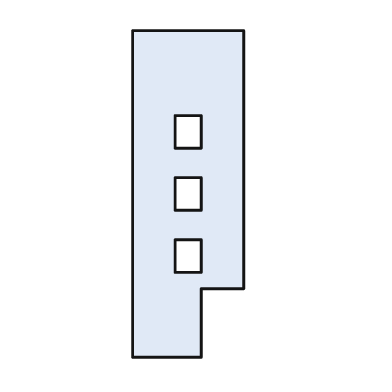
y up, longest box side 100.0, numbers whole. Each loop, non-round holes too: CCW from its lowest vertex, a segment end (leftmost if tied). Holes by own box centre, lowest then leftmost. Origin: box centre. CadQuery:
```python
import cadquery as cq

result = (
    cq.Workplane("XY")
    .moveTo(-17.0, -50.0)
    .lineTo(4.0, -50.0)
    .lineTo(4.0, -29.0)
    .lineTo(17.0, -29.0)
    .lineTo(17.0, 50.0)
    .lineTo(-17.0, 50.0)
    .close()
    .moveTo(-4.0, -24.0)
    .lineTo(4.0, -24.0)
    .lineTo(4.0, -14.0)
    .lineTo(-4.0, -14.0)
    .close()
    .moveTo(-4.0, -5.0)
    .lineTo(4.0, -5.0)
    .lineTo(4.0, 5.0)
    .lineTo(-4.0, 5.0)
    .close()
    .moveTo(-4.0, 14.0)
    .lineTo(4.0, 14.0)
    .lineTo(4.0, 24.0)
    .lineTo(-4.0, 24.0)
    .close()
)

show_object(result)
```